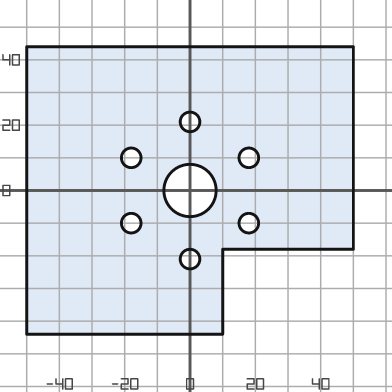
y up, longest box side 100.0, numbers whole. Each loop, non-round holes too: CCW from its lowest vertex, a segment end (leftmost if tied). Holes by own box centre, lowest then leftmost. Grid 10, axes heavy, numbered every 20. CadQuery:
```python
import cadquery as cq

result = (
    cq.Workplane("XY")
    .moveTo(-50.0, -44.0)
    .lineTo(10.0, -44.0)
    .lineTo(10.0, -18.0)
    .lineTo(50.0, -18.0)
    .lineTo(50.0, 44.0)
    .lineTo(-50.0, 44.0)
    .close()
    .moveTo(0.0, -21.0)
    .circle(3.0)
    .moveTo(-18.0, -10.0)
    .circle(3.0)
    .moveTo(18.0, -10.0)
    .circle(3.0)
    .moveTo(0.0, 0.0)
    .circle(8.0)
    .moveTo(-18.0, 10.0)
    .circle(3.0)
    .moveTo(18.0, 10.0)
    .circle(3.0)
    .moveTo(0.0, 21.0)
    .circle(3.0)
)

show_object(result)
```